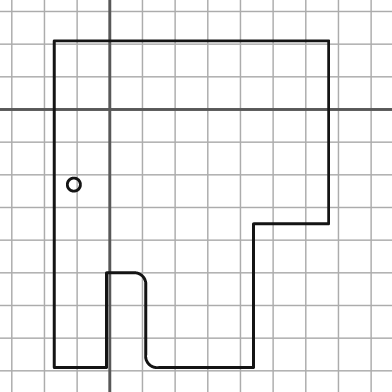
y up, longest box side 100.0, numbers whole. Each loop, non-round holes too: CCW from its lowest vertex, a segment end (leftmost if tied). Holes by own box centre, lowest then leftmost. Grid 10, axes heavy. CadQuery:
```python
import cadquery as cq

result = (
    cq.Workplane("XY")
    .moveTo(-17.0, -79.0)
    .lineTo(-1.0, -79.0)
    .lineTo(-1.0, -50.0)
    .lineTo(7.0, -50.0)
    .threePointArc((10.0, -51.0), (11.0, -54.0))
    .lineTo(11.0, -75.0)
    .threePointArc((12.0, -78.0), (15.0, -79.0))
    .lineTo(44.0, -79.0)
    .lineTo(44.0, -35.0)
    .lineTo(67.0, -35.0)
    .lineTo(67.0, 21.0)
    .lineTo(-17.0, 21.0)
    .close()
    .moveTo(-11.0, -23.0)
    .circle(2.0)
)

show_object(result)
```